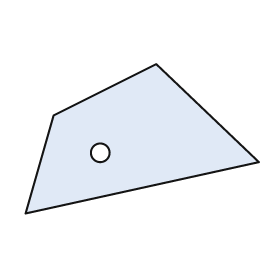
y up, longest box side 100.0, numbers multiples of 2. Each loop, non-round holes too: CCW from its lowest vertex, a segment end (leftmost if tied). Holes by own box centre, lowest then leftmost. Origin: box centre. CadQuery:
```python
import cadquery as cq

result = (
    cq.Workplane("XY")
    .moveTo(-50.0, -32.0)
    .lineTo(50.0, -10.0)
    .lineTo(6.0, 32.0)
    .lineTo(-38.0, 10.0)
    .close()
    .moveTo(-18.0, -6.0)
    .circle(4.0)
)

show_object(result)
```